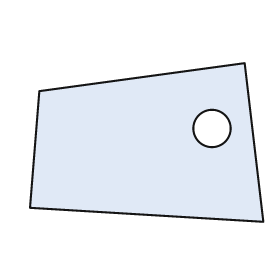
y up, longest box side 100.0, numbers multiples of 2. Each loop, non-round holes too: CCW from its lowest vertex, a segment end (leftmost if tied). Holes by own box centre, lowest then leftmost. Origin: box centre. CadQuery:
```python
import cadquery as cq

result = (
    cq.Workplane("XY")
    .moveTo(50.0, -34.0)
    .lineTo(42.0, 34.0)
    .lineTo(-46.0, 22.0)
    .lineTo(-50.0, -28.0)
    .close()
    .moveTo(28.0, 6.0)
    .circle(8.0)
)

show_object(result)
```